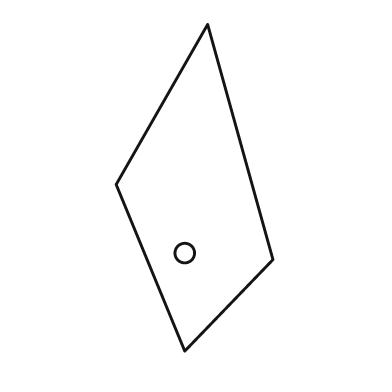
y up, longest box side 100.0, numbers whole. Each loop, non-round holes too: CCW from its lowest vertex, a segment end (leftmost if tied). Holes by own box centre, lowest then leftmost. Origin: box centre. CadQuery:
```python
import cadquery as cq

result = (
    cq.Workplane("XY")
    .moveTo(-3.0, -50.0)
    .lineTo(24.0, -22.0)
    .lineTo(4.0, 50.0)
    .lineTo(-24.0, 1.0)
    .close()
    .moveTo(-3.0, -20.0)
    .circle(3.0)
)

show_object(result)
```